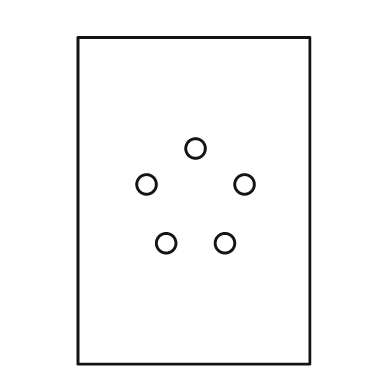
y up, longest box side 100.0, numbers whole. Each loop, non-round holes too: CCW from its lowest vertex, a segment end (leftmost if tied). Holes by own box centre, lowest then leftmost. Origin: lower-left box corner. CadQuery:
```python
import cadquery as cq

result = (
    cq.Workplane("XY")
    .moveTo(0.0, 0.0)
    .lineTo(71.0, 0.0)
    .lineTo(71.0, 100.0)
    .lineTo(0.0, 100.0)
    .close()
    .moveTo(27.0, 37.0)
    .circle(3.0)
    .moveTo(45.0, 37.0)
    .circle(3.0)
    .moveTo(21.0, 55.0)
    .circle(3.0)
    .moveTo(51.0, 55.0)
    .circle(3.0)
    .moveTo(36.0, 66.0)
    .circle(3.0)
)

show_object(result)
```